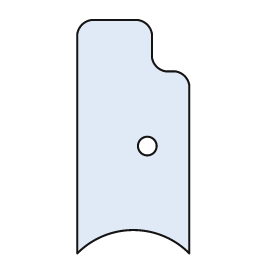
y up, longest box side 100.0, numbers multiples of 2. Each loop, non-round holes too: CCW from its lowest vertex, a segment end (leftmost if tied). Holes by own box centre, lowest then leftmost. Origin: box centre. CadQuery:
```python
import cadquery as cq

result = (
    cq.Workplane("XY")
    .moveTo(-24.0, -50.0)
    .threePointArc((0.0, -40.0), (24.0, -50.0))
    .lineTo(24.0, 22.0)
    .threePointArc((22.0, 26.0), (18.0, 28.0))
    .lineTo(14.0, 28.0)
    .threePointArc((10.0, 30.0), (8.0, 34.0))
    .lineTo(8.0, 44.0)
    .threePointArc((6.0, 48.0), (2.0, 50.0))
    .lineTo(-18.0, 50.0)
    .threePointArc((-22.0, 48.0), (-24.0, 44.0))
    .close()
    .moveTo(6.0, -4.0)
    .circle(4.0)
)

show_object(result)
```